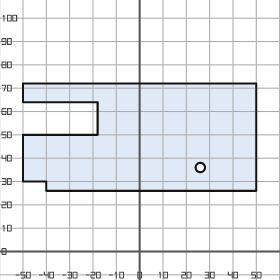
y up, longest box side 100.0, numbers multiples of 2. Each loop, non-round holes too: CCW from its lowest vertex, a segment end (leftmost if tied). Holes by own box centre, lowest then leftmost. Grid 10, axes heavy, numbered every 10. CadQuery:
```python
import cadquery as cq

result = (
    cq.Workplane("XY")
    .moveTo(-40.0, 26.0)
    .lineTo(50.0, 26.0)
    .lineTo(50.0, 72.0)
    .lineTo(-50.0, 72.0)
    .lineTo(-50.0, 64.0)
    .lineTo(-18.0, 64.0)
    .lineTo(-18.0, 50.0)
    .lineTo(-50.0, 50.0)
    .lineTo(-50.0, 30.0)
    .lineTo(-40.0, 30.0)
    .close()
    .moveTo(26.0, 36.0)
    .circle(2.0)
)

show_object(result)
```